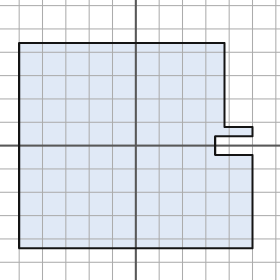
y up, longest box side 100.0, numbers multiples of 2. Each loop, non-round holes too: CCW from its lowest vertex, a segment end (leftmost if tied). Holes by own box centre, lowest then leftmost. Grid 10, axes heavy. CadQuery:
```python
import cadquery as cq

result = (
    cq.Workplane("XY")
    .moveTo(-50.0, -44.0)
    .lineTo(50.0, -44.0)
    .lineTo(50.0, -4.0)
    .lineTo(34.0, -4.0)
    .lineTo(34.0, 4.0)
    .lineTo(50.0, 4.0)
    .lineTo(50.0, 8.0)
    .lineTo(38.0, 8.0)
    .lineTo(38.0, 44.0)
    .lineTo(-50.0, 44.0)
    .close()
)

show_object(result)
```